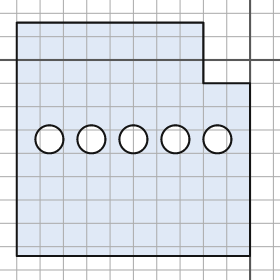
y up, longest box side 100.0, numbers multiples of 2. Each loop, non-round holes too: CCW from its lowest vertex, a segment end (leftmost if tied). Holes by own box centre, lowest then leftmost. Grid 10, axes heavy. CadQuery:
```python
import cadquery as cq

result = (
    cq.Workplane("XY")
    .moveTo(-100.0, -84.0)
    .lineTo(0.0, -84.0)
    .lineTo(0.0, -10.0)
    .lineTo(-20.0, -10.0)
    .lineTo(-20.0, 16.0)
    .lineTo(-100.0, 16.0)
    .close()
    .moveTo(-86.0, -34.0)
    .circle(6.0)
    .moveTo(-68.0, -34.0)
    .circle(6.0)
    .moveTo(-50.0, -34.0)
    .circle(6.0)
    .moveTo(-32.0, -34.0)
    .circle(6.0)
    .moveTo(-14.0, -34.0)
    .circle(6.0)
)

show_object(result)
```